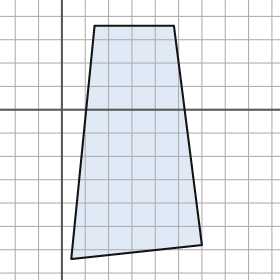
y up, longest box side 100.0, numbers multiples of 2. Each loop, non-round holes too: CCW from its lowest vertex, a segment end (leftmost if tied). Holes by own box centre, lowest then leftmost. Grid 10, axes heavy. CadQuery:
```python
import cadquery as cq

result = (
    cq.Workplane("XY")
    .moveTo(4.0, -64.0)
    .lineTo(60.0, -58.0)
    .lineTo(48.0, 36.0)
    .lineTo(14.0, 36.0)
    .close()
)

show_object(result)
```